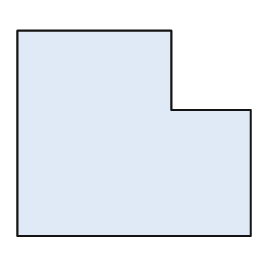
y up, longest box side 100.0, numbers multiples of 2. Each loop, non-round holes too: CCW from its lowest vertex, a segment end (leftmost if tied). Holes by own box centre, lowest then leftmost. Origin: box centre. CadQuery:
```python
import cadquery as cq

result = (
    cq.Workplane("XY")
    .moveTo(-50.0, -44.0)
    .lineTo(50.0, -44.0)
    .lineTo(50.0, 10.0)
    .lineTo(16.0, 10.0)
    .lineTo(16.0, 44.0)
    .lineTo(-50.0, 44.0)
    .close()
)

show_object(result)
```